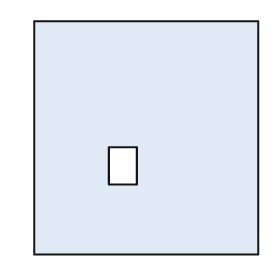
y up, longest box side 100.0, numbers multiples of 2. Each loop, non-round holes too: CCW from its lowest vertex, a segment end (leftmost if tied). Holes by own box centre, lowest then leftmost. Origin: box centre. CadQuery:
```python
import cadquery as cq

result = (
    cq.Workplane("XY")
    .moveTo(-48.0, -50.0)
    .lineTo(48.0, -50.0)
    .lineTo(48.0, 50.0)
    .lineTo(-48.0, 50.0)
    .close()
    .moveTo(-16.0, -20.0)
    .lineTo(-4.0, -20.0)
    .lineTo(-4.0, -4.0)
    .lineTo(-16.0, -4.0)
    .close()
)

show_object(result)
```